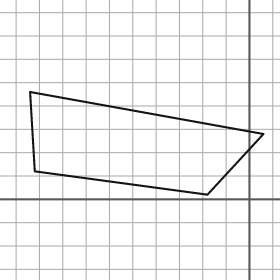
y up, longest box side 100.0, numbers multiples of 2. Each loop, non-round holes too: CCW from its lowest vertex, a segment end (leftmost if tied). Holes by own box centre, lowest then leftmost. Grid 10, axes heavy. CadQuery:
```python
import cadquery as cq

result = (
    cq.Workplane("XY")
    .moveTo(-18.0, 2.0)
    .lineTo(6.0, 28.0)
    .lineTo(-94.0, 46.0)
    .lineTo(-92.0, 12.0)
    .close()
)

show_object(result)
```